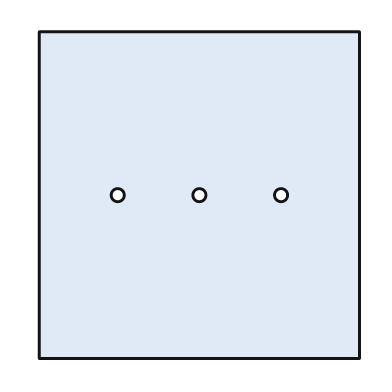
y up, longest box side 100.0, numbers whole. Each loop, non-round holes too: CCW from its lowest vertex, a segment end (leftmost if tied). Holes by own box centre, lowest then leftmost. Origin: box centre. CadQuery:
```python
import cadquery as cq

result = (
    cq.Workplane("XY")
    .moveTo(-49.0, -50.0)
    .lineTo(49.0, -50.0)
    .lineTo(49.0, 50.0)
    .lineTo(-49.0, 50.0)
    .close()
    .moveTo(-25.0, 0.0)
    .circle(2.0)
    .moveTo(0.0, 0.0)
    .circle(2.0)
    .moveTo(25.0, 0.0)
    .circle(2.0)
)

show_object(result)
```